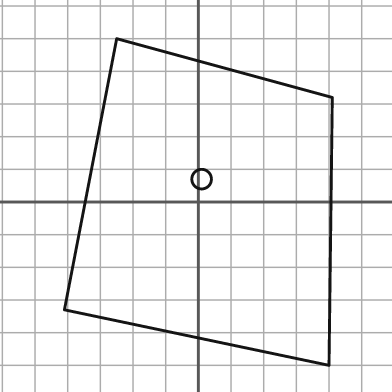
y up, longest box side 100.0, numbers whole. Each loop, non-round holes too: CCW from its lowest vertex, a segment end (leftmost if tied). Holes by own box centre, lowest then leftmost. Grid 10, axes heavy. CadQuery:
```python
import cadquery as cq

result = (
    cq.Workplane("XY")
    .moveTo(40.0, -50.0)
    .lineTo(41.0, 32.0)
    .lineTo(-25.0, 50.0)
    .lineTo(-41.0, -33.0)
    .close()
    .moveTo(1.0, 7.0)
    .circle(3.0)
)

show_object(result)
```